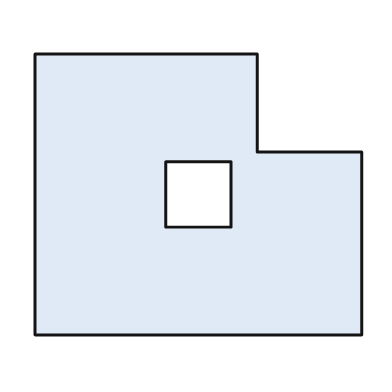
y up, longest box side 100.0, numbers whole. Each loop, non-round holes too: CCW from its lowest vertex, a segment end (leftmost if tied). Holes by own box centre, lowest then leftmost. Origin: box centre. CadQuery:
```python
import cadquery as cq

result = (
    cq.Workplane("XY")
    .moveTo(-50.0, -43.0)
    .lineTo(50.0, -43.0)
    .lineTo(50.0, 13.0)
    .lineTo(18.0, 13.0)
    .lineTo(18.0, 43.0)
    .lineTo(-50.0, 43.0)
    .close()
    .moveTo(-10.0, -10.0)
    .lineTo(10.0, -10.0)
    .lineTo(10.0, 10.0)
    .lineTo(-10.0, 10.0)
    .close()
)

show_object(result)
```